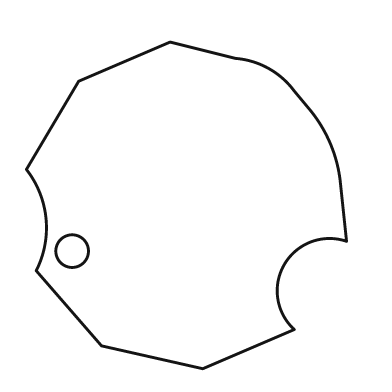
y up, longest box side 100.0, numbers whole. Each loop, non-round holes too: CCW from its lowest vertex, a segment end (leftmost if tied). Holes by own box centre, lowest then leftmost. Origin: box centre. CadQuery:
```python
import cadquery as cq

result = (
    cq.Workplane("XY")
    .moveTo(5.0, -50.0)
    .lineTo(33.0, -38.0)
    .threePointArc((30.0, -18.0), (49.0, -11.0))
    .lineTo(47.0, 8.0)
    .threePointArc((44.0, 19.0), (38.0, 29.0))
    .lineTo(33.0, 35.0)
    .threePointArc((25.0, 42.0), (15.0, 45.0))
    .lineTo(-5.0, 50.0)
    .lineTo(-33.0, 38.0)
    .lineTo(-49.0, 11.0)
    .threePointArc((-43.0, -4.0), (-46.0, -20.0))
    .lineTo(-26.0, -43.0)
    .close()
    .moveTo(-35.0, -14.0)
    .circle(5.0)
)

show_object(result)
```